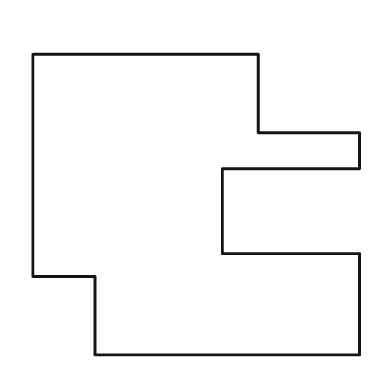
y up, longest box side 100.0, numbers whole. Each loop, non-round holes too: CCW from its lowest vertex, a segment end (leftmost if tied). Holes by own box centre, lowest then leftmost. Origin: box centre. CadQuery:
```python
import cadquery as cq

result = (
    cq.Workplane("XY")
    .moveTo(-31.0, -46.0)
    .lineTo(50.0, -46.0)
    .lineTo(50.0, -15.0)
    .lineTo(8.0, -15.0)
    .lineTo(8.0, 11.0)
    .lineTo(50.0, 11.0)
    .lineTo(50.0, 22.0)
    .lineTo(19.0, 22.0)
    .lineTo(19.0, 46.0)
    .lineTo(-50.0, 46.0)
    .lineTo(-50.0, -22.0)
    .lineTo(-31.0, -22.0)
    .close()
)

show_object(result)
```